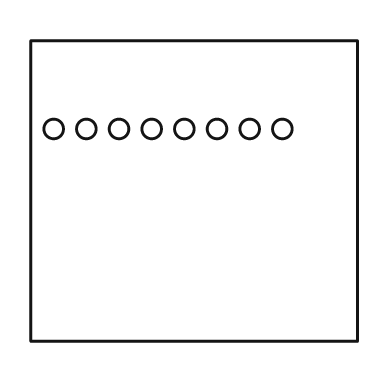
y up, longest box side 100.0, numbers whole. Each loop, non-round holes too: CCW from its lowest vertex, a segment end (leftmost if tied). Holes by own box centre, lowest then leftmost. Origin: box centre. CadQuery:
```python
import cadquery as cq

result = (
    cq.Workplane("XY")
    .moveTo(-50.0, -46.0)
    .lineTo(50.0, -46.0)
    .lineTo(50.0, 46.0)
    .lineTo(-50.0, 46.0)
    .close()
    .moveTo(-43.0, 19.0)
    .circle(3.0)
    .moveTo(-33.0, 19.0)
    .circle(3.0)
    .moveTo(-23.0, 19.0)
    .circle(3.0)
    .moveTo(-13.0, 19.0)
    .circle(3.0)
    .moveTo(-3.0, 19.0)
    .circle(3.0)
    .moveTo(7.0, 19.0)
    .circle(3.0)
    .moveTo(17.0, 19.0)
    .circle(3.0)
    .moveTo(27.0, 19.0)
    .circle(3.0)
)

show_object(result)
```